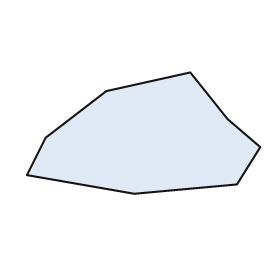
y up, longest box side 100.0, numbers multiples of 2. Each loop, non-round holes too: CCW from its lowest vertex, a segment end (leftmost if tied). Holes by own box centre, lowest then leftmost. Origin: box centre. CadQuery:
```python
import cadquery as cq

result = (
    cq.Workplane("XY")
    .moveTo(-4.0, -26.0)
    .lineTo(40.0, -22.0)
    .lineTo(50.0, -6.0)
    .lineTo(36.0, 6.0)
    .lineTo(20.0, 26.0)
    .lineTo(-16.0, 18.0)
    .lineTo(-42.0, -2.0)
    .lineTo(-50.0, -18.0)
    .close()
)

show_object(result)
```